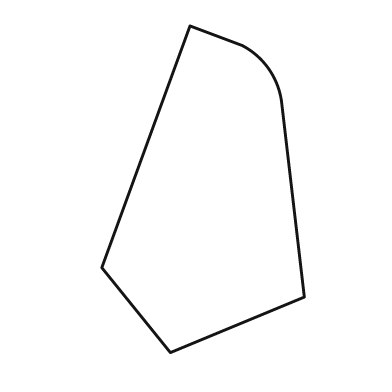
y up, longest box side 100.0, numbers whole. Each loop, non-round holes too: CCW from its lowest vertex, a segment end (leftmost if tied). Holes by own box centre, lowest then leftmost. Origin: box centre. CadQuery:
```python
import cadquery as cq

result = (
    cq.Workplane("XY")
    .moveTo(-10.0, -50.0)
    .lineTo(31.0, -33.0)
    .lineTo(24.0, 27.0)
    .threePointArc((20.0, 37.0), (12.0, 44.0))
    .lineTo(-4.0, 50.0)
    .lineTo(-31.0, -24.0)
    .close()
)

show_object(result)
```